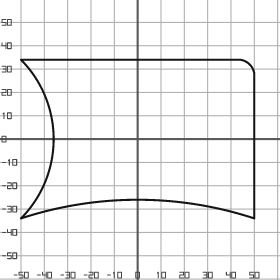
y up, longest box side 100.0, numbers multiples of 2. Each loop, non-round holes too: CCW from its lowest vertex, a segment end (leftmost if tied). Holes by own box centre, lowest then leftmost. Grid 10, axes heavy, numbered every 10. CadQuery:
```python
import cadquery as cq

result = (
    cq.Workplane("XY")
    .moveTo(-50.0, -34.0)
    .threePointArc((0.0, -26.0), (50.0, -34.0))
    .lineTo(50.0, 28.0)
    .threePointArc((48.0, 32.0), (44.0, 34.0))
    .lineTo(-50.0, 34.0)
    .threePointArc((-36.0, 0.0), (-50.0, -34.0))
    .close()
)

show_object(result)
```